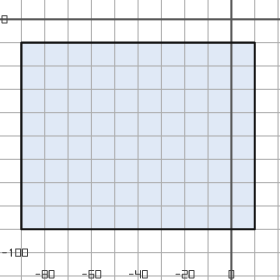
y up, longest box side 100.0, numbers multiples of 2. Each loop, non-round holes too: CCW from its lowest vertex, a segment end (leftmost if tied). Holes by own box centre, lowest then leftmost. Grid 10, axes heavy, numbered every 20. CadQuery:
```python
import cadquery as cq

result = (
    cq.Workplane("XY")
    .moveTo(-90.0, -90.0)
    .lineTo(10.0, -90.0)
    .lineTo(10.0, -10.0)
    .lineTo(-90.0, -10.0)
    .close()
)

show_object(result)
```